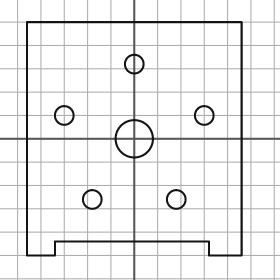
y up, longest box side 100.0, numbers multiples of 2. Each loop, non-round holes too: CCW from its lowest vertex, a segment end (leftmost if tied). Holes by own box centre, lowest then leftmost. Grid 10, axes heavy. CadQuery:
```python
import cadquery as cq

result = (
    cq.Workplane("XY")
    .moveTo(-46.0, -50.0)
    .lineTo(-34.0, -50.0)
    .lineTo(-34.0, -44.0)
    .lineTo(32.0, -44.0)
    .lineTo(32.0, -50.0)
    .lineTo(46.0, -50.0)
    .lineTo(46.0, 50.0)
    .lineTo(-46.0, 50.0)
    .close()
    .moveTo(-18.0, -26.0)
    .circle(4.0)
    .moveTo(18.0, -26.0)
    .circle(4.0)
    .moveTo(0.0, 0.0)
    .circle(8.0)
    .moveTo(-30.0, 10.0)
    .circle(4.0)
    .moveTo(30.0, 10.0)
    .circle(4.0)
    .moveTo(0.0, 32.0)
    .circle(4.0)
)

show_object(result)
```